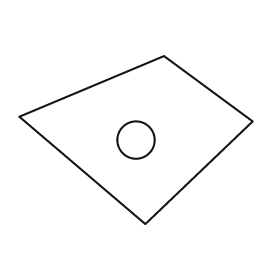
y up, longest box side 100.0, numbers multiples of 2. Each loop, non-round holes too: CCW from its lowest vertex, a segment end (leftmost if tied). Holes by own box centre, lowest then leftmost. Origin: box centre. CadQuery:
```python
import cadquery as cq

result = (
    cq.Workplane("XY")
    .moveTo(4.0, -36.0)
    .lineTo(50.0, 8.0)
    .lineTo(12.0, 36.0)
    .lineTo(-50.0, 10.0)
    .close()
    .moveTo(0.0, 0.0)
    .circle(8.0)
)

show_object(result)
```